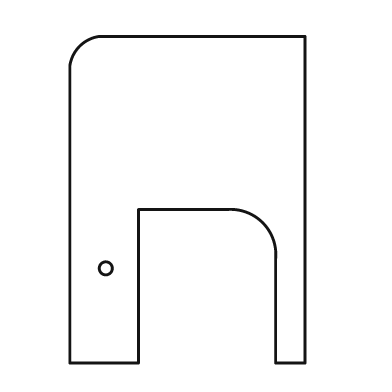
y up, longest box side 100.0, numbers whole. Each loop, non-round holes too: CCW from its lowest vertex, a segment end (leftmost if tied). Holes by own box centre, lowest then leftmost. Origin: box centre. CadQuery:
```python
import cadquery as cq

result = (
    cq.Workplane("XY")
    .moveTo(-36.0, -50.0)
    .lineTo(-15.0, -50.0)
    .lineTo(-15.0, -3.0)
    .lineTo(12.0, -3.0)
    .threePointArc((23.0, -7.0), (27.0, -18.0))
    .lineTo(27.0, -50.0)
    .lineTo(36.0, -50.0)
    .lineTo(36.0, 50.0)
    .lineTo(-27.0, 50.0)
    .threePointArc((-33.0, 47.0), (-36.0, 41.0))
    .close()
    .moveTo(-25.0, -21.0)
    .circle(2.0)
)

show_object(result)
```